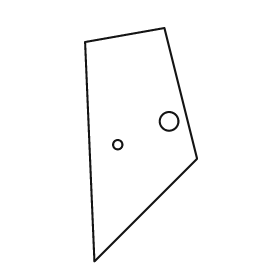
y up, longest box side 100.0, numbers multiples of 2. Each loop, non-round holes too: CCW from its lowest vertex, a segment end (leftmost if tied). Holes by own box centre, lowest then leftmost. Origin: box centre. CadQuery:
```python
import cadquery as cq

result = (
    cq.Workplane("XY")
    .moveTo(-20.0, -50.0)
    .lineTo(24.0, -6.0)
    .lineTo(10.0, 50.0)
    .lineTo(-24.0, 44.0)
    .close()
    .moveTo(-10.0, 0.0)
    .circle(2.0)
    .moveTo(12.0, 10.0)
    .circle(4.0)
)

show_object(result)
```